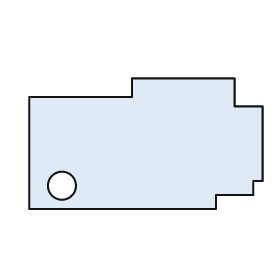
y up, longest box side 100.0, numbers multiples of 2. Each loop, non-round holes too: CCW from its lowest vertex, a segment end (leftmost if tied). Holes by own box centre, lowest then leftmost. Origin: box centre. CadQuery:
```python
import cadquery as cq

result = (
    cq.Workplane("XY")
    .moveTo(-50.0, -28.0)
    .lineTo(30.0, -28.0)
    .lineTo(30.0, -22.0)
    .lineTo(46.0, -22.0)
    .lineTo(46.0, -16.0)
    .lineTo(50.0, -16.0)
    .lineTo(50.0, 16.0)
    .lineTo(38.0, 16.0)
    .lineTo(38.0, 28.0)
    .lineTo(-6.0, 28.0)
    .lineTo(-6.0, 20.0)
    .lineTo(-50.0, 20.0)
    .close()
    .moveTo(-36.0, -18.0)
    .circle(6.0)
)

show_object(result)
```